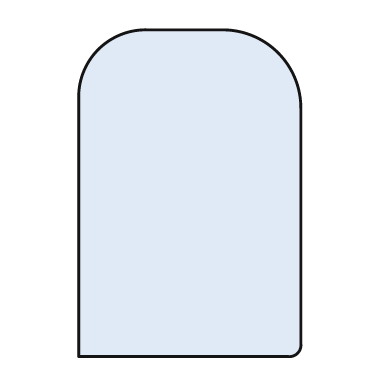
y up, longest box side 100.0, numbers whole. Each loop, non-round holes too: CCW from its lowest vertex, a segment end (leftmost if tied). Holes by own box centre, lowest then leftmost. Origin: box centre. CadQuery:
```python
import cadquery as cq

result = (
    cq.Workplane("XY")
    .moveTo(-34.0, -50.0)
    .lineTo(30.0, -50.0)
    .threePointArc((33.0, -49.0), (34.0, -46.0))
    .lineTo(34.0, 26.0)
    .threePointArc((27.0, 43.0), (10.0, 50.0))
    .lineTo(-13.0, 50.0)
    .threePointArc((-28.0, 44.0), (-34.0, 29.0))
    .close()
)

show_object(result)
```